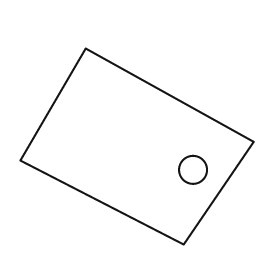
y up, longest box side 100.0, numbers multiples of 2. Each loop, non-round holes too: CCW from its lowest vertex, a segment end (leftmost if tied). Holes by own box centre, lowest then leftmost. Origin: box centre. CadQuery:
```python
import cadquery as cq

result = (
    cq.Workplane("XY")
    .moveTo(20.0, -42.0)
    .lineTo(50.0, 2.0)
    .lineTo(-22.0, 42.0)
    .lineTo(-50.0, -6.0)
    .close()
    .moveTo(24.0, -10.0)
    .circle(6.0)
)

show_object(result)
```